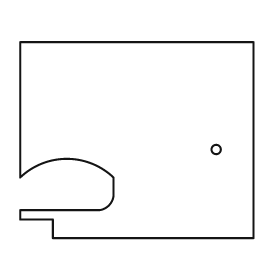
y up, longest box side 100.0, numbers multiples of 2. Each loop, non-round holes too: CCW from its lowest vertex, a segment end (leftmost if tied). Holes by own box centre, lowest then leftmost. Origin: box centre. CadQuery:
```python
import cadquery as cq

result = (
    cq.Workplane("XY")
    .moveTo(-36.0, -42.0)
    .lineTo(50.0, -42.0)
    .lineTo(50.0, 42.0)
    .lineTo(-50.0, 42.0)
    .lineTo(-50.0, -16.0)
    .threePointArc((-30.0, -8.0), (-10.0, -16.0))
    .lineTo(-10.0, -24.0)
    .threePointArc((-12.0, -28.0), (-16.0, -30.0))
    .lineTo(-50.0, -30.0)
    .lineTo(-50.0, -34.0)
    .lineTo(-36.0, -34.0)
    .close()
    .moveTo(34.0, -4.0)
    .circle(2.0)
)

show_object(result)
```